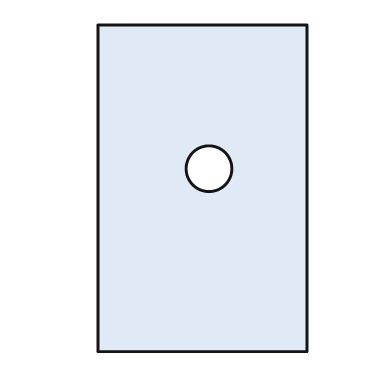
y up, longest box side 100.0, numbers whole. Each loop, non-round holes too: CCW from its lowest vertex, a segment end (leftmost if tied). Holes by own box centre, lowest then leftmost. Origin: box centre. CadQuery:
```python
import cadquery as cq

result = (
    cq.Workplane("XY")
    .moveTo(-32.0, -50.0)
    .lineTo(32.0, -50.0)
    .lineTo(32.0, 50.0)
    .lineTo(-32.0, 50.0)
    .close()
    .moveTo(2.0, 6.0)
    .circle(7.0)
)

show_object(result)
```